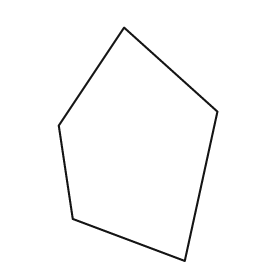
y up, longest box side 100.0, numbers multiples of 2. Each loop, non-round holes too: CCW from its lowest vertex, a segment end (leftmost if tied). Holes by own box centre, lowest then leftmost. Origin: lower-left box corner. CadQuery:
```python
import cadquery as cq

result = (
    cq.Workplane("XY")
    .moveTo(54.0, 0.0)
    .lineTo(68.0, 64.0)
    .lineTo(28.0, 100.0)
    .lineTo(0.0, 58.0)
    .lineTo(6.0, 18.0)
    .close()
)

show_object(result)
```